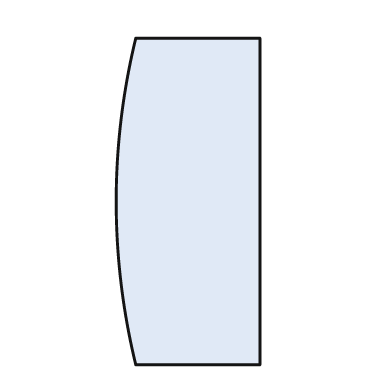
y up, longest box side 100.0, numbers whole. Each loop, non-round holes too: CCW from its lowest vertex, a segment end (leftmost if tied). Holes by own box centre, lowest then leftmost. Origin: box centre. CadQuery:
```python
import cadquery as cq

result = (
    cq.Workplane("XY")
    .moveTo(-16.0, -50.0)
    .lineTo(22.0, -50.0)
    .lineTo(22.0, 50.0)
    .lineTo(-16.0, 50.0)
    .threePointArc((-22.0, 0.0), (-16.0, -50.0))
    .close()
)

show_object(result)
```